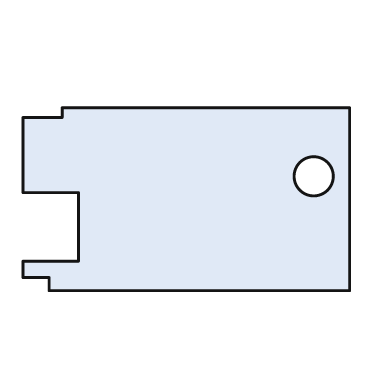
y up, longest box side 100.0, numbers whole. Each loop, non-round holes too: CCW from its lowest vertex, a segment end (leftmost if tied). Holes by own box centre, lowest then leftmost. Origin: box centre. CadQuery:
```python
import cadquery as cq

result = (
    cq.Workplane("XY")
    .moveTo(-42.0, -28.0)
    .lineTo(50.0, -28.0)
    .lineTo(50.0, 28.0)
    .lineTo(-38.0, 28.0)
    .lineTo(-38.0, 25.0)
    .lineTo(-50.0, 25.0)
    .lineTo(-50.0, 2.0)
    .lineTo(-33.0, 2.0)
    .lineTo(-33.0, -19.0)
    .lineTo(-50.0, -19.0)
    .lineTo(-50.0, -24.0)
    .lineTo(-42.0, -24.0)
    .close()
    .moveTo(39.0, 7.0)
    .circle(6.0)
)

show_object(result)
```